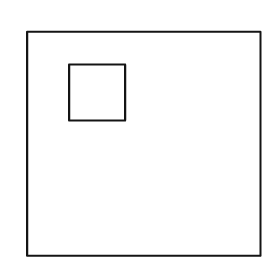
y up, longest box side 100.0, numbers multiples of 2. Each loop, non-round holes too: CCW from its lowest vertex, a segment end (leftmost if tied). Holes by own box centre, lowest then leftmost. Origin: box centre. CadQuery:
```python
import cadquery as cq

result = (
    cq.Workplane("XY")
    .moveTo(-50.0, -48.0)
    .lineTo(50.0, -48.0)
    .lineTo(50.0, 48.0)
    .lineTo(-50.0, 48.0)
    .close()
    .moveTo(-32.0, 10.0)
    .lineTo(-8.0, 10.0)
    .lineTo(-8.0, 34.0)
    .lineTo(-32.0, 34.0)
    .close()
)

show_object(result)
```